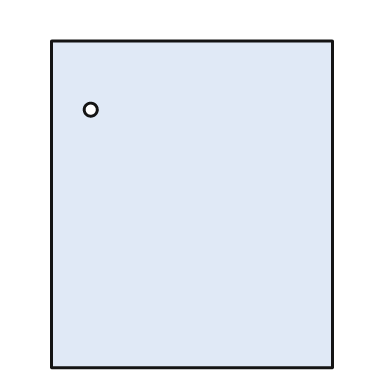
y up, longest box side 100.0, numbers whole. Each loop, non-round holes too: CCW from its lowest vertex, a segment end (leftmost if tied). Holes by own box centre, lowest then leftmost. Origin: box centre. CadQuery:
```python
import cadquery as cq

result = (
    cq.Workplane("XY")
    .moveTo(-43.0, -50.0)
    .lineTo(43.0, -50.0)
    .lineTo(43.0, 50.0)
    .lineTo(-43.0, 50.0)
    .close()
    .moveTo(-31.0, 29.0)
    .circle(2.0)
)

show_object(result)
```